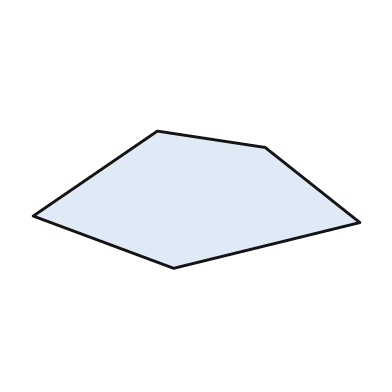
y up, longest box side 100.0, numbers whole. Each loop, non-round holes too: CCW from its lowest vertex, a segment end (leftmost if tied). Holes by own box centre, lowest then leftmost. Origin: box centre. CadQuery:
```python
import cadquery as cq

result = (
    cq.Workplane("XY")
    .moveTo(-7.0, -21.0)
    .lineTo(50.0, -7.0)
    .lineTo(21.0, 16.0)
    .lineTo(-12.0, 21.0)
    .lineTo(-50.0, -5.0)
    .close()
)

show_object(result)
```